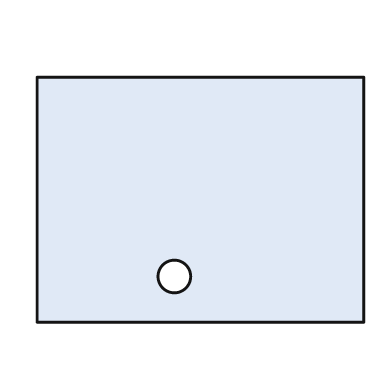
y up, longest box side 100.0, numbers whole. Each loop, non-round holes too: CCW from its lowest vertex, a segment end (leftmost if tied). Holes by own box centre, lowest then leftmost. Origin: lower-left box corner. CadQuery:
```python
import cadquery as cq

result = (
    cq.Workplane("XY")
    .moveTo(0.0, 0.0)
    .lineTo(100.0, 0.0)
    .lineTo(100.0, 75.0)
    .lineTo(0.0, 75.0)
    .close()
    .moveTo(42.0, 14.0)
    .circle(5.0)
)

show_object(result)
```